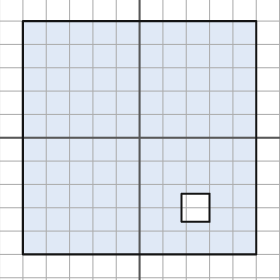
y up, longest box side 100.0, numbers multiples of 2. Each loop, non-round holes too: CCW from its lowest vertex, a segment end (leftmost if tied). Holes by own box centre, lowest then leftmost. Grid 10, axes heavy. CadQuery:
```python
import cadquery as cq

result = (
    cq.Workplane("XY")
    .moveTo(-50.0, -50.0)
    .lineTo(50.0, -50.0)
    .lineTo(50.0, 50.0)
    .lineTo(-50.0, 50.0)
    .close()
    .moveTo(18.0, -36.0)
    .lineTo(30.0, -36.0)
    .lineTo(30.0, -24.0)
    .lineTo(18.0, -24.0)
    .close()
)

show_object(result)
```